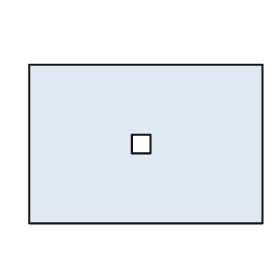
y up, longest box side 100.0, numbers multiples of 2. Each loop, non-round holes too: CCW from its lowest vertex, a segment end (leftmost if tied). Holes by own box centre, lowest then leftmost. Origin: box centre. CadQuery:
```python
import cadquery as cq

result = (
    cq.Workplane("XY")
    .moveTo(-50.0, -34.0)
    .lineTo(50.0, -34.0)
    .lineTo(50.0, 34.0)
    .lineTo(-50.0, 34.0)
    .close()
    .moveTo(-6.0, -4.0)
    .lineTo(2.0, -4.0)
    .lineTo(2.0, 4.0)
    .lineTo(-6.0, 4.0)
    .close()
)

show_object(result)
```